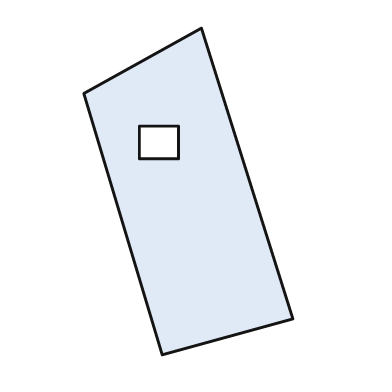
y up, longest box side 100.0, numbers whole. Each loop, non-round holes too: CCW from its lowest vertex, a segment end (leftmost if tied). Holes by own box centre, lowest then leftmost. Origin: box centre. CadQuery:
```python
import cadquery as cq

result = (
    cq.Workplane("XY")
    .moveTo(-8.0, -50.0)
    .lineTo(32.0, -39.0)
    .lineTo(4.0, 50.0)
    .lineTo(-32.0, 30.0)
    .close()
    .moveTo(-15.0, 10.0)
    .lineTo(-3.0, 10.0)
    .lineTo(-3.0, 20.0)
    .lineTo(-15.0, 20.0)
    .close()
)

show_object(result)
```